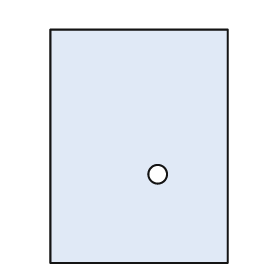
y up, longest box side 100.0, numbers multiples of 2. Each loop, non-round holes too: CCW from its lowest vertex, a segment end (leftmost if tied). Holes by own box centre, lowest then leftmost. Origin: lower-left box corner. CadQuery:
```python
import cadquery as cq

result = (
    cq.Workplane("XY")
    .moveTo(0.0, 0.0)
    .lineTo(76.0, 0.0)
    .lineTo(76.0, 100.0)
    .lineTo(0.0, 100.0)
    .close()
    .moveTo(46.0, 38.0)
    .circle(4.0)
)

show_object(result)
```